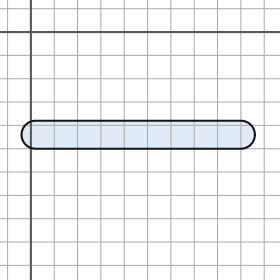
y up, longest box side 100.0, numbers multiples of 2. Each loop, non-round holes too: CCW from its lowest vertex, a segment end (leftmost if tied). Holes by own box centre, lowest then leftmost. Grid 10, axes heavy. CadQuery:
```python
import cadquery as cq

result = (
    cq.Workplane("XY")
    .moveTo(2.0, -50.0)
    .lineTo(90.0, -50.0)
    .threePointArc((96.0, -44.0), (90.0, -38.0))
    .lineTo(2.0, -38.0)
    .threePointArc((-4.0, -44.0), (2.0, -50.0))
    .close()
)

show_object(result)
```